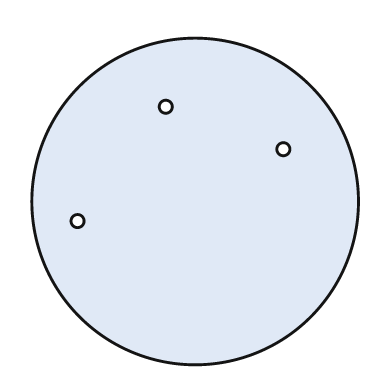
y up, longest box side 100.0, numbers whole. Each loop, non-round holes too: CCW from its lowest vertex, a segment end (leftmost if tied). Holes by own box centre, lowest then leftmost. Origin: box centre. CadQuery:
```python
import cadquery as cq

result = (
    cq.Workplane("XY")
    .moveTo(0.0, 0.0)
    .circle(50.0)
    .moveTo(-36.0, -6.0)
    .circle(2.0)
    .moveTo(27.0, 16.0)
    .circle(2.0)
    .moveTo(-9.0, 29.0)
    .circle(2.0)
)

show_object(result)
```